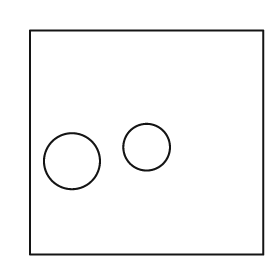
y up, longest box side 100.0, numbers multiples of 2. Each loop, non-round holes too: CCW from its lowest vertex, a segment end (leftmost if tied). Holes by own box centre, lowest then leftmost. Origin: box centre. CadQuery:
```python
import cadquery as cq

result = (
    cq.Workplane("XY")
    .moveTo(-50.0, -48.0)
    .lineTo(50.0, -48.0)
    .lineTo(50.0, 48.0)
    .lineTo(-50.0, 48.0)
    .close()
    .moveTo(-32.0, -8.0)
    .circle(12.0)
    .moveTo(0.0, -2.0)
    .circle(10.0)
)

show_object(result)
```